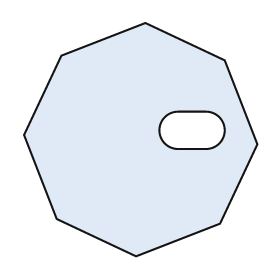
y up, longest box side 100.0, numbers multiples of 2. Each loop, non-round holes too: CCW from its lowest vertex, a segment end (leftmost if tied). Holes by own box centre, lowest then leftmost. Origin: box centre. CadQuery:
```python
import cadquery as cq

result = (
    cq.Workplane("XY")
    .moveTo(-2.0, -50.0)
    .lineTo(34.0, -36.0)
    .lineTo(50.0, -2.0)
    .lineTo(36.0, 34.0)
    .lineTo(2.0, 50.0)
    .lineTo(-34.0, 36.0)
    .lineTo(-50.0, 2.0)
    .lineTo(-36.0, -34.0)
    .close()
    .moveTo(16.0, -4.0)
    .lineTo(28.0, -4.0)
    .threePointArc((36.0, 4.0), (28.0, 12.0))
    .lineTo(16.0, 12.0)
    .threePointArc((8.0, 4.0), (16.0, -4.0))
    .close()
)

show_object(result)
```